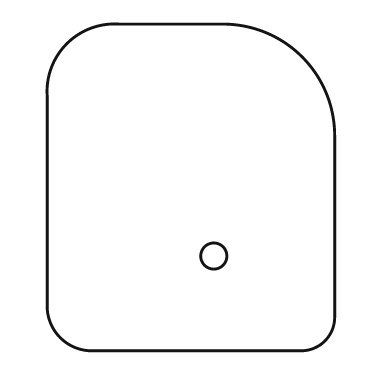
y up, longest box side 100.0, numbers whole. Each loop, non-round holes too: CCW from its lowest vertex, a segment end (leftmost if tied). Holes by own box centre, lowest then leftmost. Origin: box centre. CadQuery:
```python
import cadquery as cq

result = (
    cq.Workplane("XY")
    .moveTo(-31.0, -50.0)
    .lineTo(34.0, -50.0)
    .threePointArc((41.0, -47.0), (44.0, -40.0))
    .lineTo(44.0, 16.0)
    .threePointArc((34.0, 40.0), (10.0, 50.0))
    .lineTo(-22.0, 50.0)
    .threePointArc((-38.0, 44.0), (-44.0, 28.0))
    .lineTo(-44.0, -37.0)
    .threePointArc((-40.0, -46.0), (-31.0, -50.0))
    .close()
    .moveTo(7.0, -21.0)
    .circle(4.0)
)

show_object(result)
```